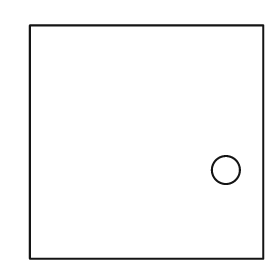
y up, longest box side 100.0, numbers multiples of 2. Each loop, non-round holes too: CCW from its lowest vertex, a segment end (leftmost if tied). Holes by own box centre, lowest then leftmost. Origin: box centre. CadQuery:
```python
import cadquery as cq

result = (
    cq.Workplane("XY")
    .moveTo(-50.0, -50.0)
    .lineTo(50.0, -50.0)
    .lineTo(50.0, 50.0)
    .lineTo(-50.0, 50.0)
    .close()
    .moveTo(34.0, -12.0)
    .circle(6.0)
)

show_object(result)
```